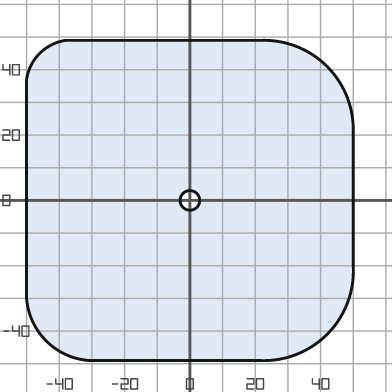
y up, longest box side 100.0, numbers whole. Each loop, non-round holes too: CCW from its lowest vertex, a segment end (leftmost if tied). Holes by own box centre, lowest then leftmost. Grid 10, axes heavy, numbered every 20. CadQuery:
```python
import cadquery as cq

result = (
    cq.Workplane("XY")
    .moveTo(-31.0, -49.0)
    .lineTo(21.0, -49.0)
    .threePointArc((42.0, -41.0), (50.0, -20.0))
    .lineTo(50.0, 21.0)
    .threePointArc((42.0, 41.0), (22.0, 49.0))
    .lineTo(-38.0, 49.0)
    .threePointArc((-46.0, 45.0), (-50.0, 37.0))
    .lineTo(-50.0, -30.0)
    .threePointArc((-44.0, -43.0), (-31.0, -49.0))
    .close()
    .moveTo(0.0, 0.0)
    .circle(3.0)
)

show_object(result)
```